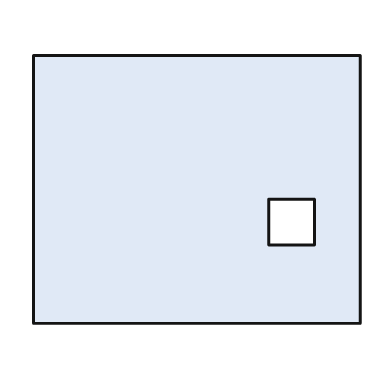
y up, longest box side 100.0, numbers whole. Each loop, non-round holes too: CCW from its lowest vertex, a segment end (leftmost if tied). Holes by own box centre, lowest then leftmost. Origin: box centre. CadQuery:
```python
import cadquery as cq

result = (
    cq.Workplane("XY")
    .moveTo(-50.0, -41.0)
    .lineTo(50.0, -41.0)
    .lineTo(50.0, 41.0)
    .lineTo(-50.0, 41.0)
    .close()
    .moveTo(22.0, -17.0)
    .lineTo(36.0, -17.0)
    .lineTo(36.0, -3.0)
    .lineTo(22.0, -3.0)
    .close()
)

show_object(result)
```